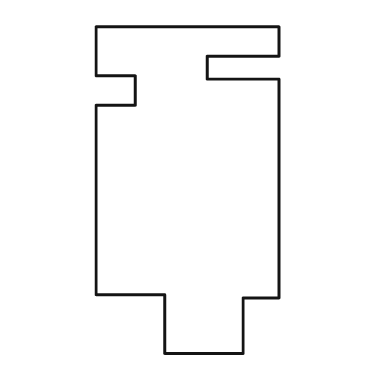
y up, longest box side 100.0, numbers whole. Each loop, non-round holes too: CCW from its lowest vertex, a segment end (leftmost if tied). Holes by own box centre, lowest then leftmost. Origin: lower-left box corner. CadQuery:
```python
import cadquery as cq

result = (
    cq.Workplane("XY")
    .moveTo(21.0, 0.0)
    .lineTo(45.0, 0.0)
    .lineTo(45.0, 17.0)
    .lineTo(56.0, 17.0)
    .lineTo(56.0, 84.0)
    .lineTo(34.0, 84.0)
    .lineTo(34.0, 91.0)
    .lineTo(56.0, 91.0)
    .lineTo(56.0, 100.0)
    .lineTo(0.0, 100.0)
    .lineTo(0.0, 85.0)
    .lineTo(12.0, 85.0)
    .lineTo(12.0, 76.0)
    .lineTo(0.0, 76.0)
    .lineTo(0.0, 18.0)
    .lineTo(21.0, 18.0)
    .close()
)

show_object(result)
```